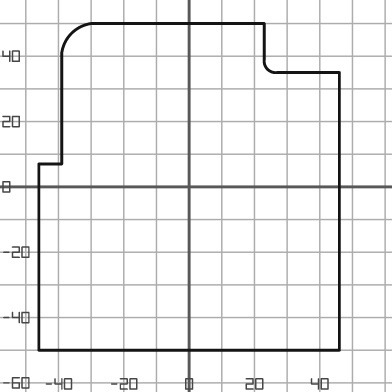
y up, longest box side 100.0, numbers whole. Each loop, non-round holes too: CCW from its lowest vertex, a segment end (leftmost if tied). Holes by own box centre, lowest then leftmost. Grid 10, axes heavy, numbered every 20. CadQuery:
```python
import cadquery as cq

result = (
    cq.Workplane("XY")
    .moveTo(-46.0, -50.0)
    .lineTo(46.0, -50.0)
    .lineTo(46.0, 35.0)
    .lineTo(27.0, 35.0)
    .threePointArc((24.0, 36.0), (23.0, 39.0))
    .lineTo(23.0, 50.0)
    .lineTo(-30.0, 50.0)
    .threePointArc((-36.0, 47.0), (-39.0, 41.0))
    .lineTo(-39.0, 7.0)
    .lineTo(-46.0, 7.0)
    .close()
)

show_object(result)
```